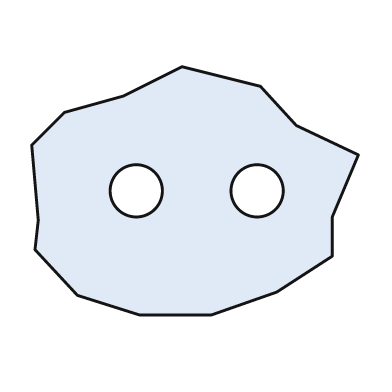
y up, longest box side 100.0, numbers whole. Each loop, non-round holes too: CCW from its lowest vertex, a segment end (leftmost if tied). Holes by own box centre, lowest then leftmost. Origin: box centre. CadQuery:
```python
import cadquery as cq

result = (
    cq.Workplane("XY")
    .moveTo(-17.0, -38.0)
    .lineTo(5.0, -38.0)
    .lineTo(25.0, -31.0)
    .lineTo(42.0, -20.0)
    .lineTo(42.0, -8.0)
    .lineTo(50.0, 11.0)
    .lineTo(31.0, 20.0)
    .lineTo(20.0, 32.0)
    .lineTo(-4.0, 38.0)
    .lineTo(-22.0, 29.0)
    .lineTo(-40.0, 24.0)
    .lineTo(-50.0, 14.0)
    .lineTo(-48.0, -9.0)
    .lineTo(-49.0, -18.0)
    .lineTo(-36.0, -32.0)
    .close()
    .moveTo(-18.0, 0.0)
    .circle(8.0)
    .moveTo(19.0, 0.0)
    .circle(8.0)
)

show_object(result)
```